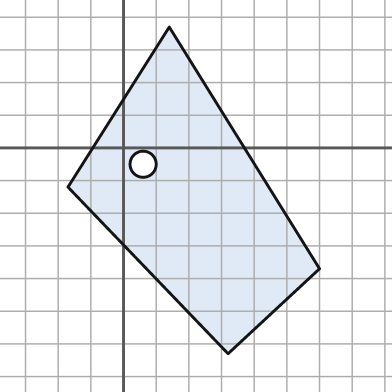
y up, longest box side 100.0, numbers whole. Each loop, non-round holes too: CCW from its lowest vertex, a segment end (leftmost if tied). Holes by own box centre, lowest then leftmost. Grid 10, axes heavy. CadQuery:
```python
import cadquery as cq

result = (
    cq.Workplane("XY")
    .moveTo(32.0, -63.0)
    .lineTo(60.0, -37.0)
    .lineTo(14.0, 37.0)
    .lineTo(-17.0, -12.0)
    .close()
    .moveTo(6.0, -5.0)
    .circle(4.0)
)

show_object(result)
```